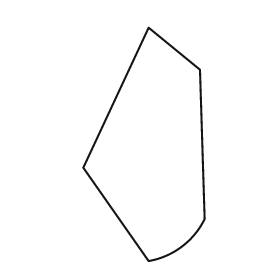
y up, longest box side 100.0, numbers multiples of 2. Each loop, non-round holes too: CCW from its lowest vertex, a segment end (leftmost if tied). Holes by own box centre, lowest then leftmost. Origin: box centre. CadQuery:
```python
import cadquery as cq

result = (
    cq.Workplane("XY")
    .moveTo(2.0, -50.0)
    .threePointArc((16.0, -44.0), (26.0, -32.0))
    .lineTo(24.0, 32.0)
    .lineTo(2.0, 50.0)
    .lineTo(-26.0, -10.0)
    .close()
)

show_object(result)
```